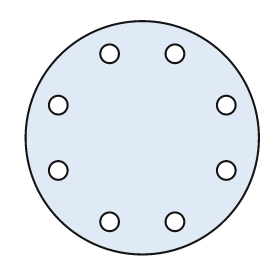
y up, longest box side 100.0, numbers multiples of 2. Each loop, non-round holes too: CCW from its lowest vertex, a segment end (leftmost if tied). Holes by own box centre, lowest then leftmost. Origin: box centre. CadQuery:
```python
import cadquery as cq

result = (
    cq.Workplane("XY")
    .moveTo(0.0, 0.0)
    .circle(50.0)
    .moveTo(-14.0, -36.0)
    .circle(4.0)
    .moveTo(14.0, -36.0)
    .circle(4.0)
    .moveTo(-36.0, -14.0)
    .circle(4.0)
    .moveTo(36.0, -14.0)
    .circle(4.0)
    .moveTo(-36.0, 14.0)
    .circle(4.0)
    .moveTo(36.0, 14.0)
    .circle(4.0)
    .moveTo(-14.0, 36.0)
    .circle(4.0)
    .moveTo(14.0, 36.0)
    .circle(4.0)
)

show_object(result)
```